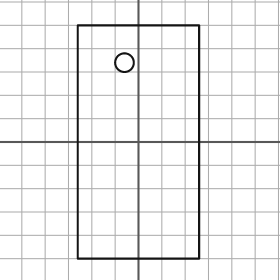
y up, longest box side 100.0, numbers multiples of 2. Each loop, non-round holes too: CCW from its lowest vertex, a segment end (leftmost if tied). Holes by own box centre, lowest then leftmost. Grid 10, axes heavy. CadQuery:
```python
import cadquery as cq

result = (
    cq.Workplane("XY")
    .moveTo(-26.0, -50.0)
    .lineTo(26.0, -50.0)
    .lineTo(26.0, 50.0)
    .lineTo(-26.0, 50.0)
    .close()
    .moveTo(-6.0, 34.0)
    .circle(4.0)
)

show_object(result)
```